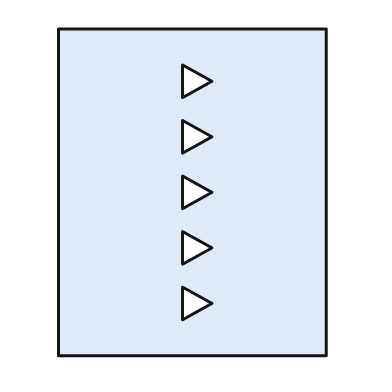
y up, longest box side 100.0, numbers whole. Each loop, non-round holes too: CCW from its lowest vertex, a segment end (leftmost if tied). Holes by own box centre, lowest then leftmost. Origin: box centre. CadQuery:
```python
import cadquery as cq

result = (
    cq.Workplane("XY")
    .moveTo(-41.0, -50.0)
    .lineTo(41.0, -50.0)
    .lineTo(41.0, 50.0)
    .lineTo(-41.0, 50.0)
    .close()
    .moveTo(-3.0, -39.0)
    .lineTo(6.0, -34.0)
    .lineTo(-3.0, -29.0)
    .close()
    .moveTo(-3.0, -22.0)
    .lineTo(6.0, -17.0)
    .lineTo(-3.0, -12.0)
    .close()
    .moveTo(-3.0, -5.0)
    .lineTo(6.0, 0.0)
    .lineTo(-3.0, 5.0)
    .close()
    .moveTo(-3.0, 12.0)
    .lineTo(6.0, 17.0)
    .lineTo(-3.0, 22.0)
    .close()
    .moveTo(-3.0, 29.0)
    .lineTo(6.0, 34.0)
    .lineTo(-3.0, 39.0)
    .close()
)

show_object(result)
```